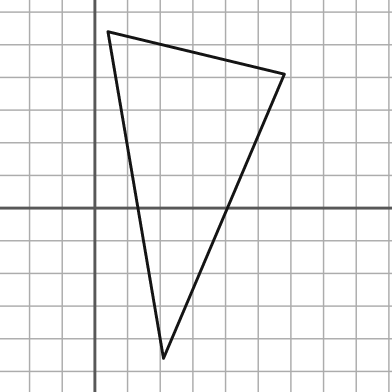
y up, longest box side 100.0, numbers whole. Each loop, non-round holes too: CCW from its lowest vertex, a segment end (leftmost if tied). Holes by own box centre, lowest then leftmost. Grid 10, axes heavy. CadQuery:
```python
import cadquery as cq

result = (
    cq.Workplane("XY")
    .moveTo(21.0, -46.0)
    .lineTo(58.0, 41.0)
    .lineTo(4.0, 54.0)
    .close()
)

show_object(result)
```